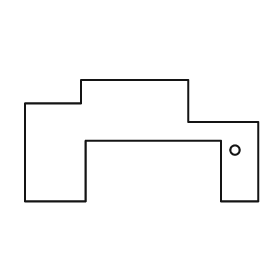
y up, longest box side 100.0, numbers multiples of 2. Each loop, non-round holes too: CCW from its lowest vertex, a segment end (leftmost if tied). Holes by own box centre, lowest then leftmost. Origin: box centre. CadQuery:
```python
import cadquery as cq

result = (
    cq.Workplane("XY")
    .moveTo(-50.0, -26.0)
    .lineTo(-24.0, -26.0)
    .lineTo(-24.0, 0.0)
    .lineTo(34.0, 0.0)
    .lineTo(34.0, -26.0)
    .lineTo(50.0, -26.0)
    .lineTo(50.0, 8.0)
    .lineTo(20.0, 8.0)
    .lineTo(20.0, 26.0)
    .lineTo(-26.0, 26.0)
    .lineTo(-26.0, 16.0)
    .lineTo(-50.0, 16.0)
    .close()
    .moveTo(40.0, -4.0)
    .circle(2.0)
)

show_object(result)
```